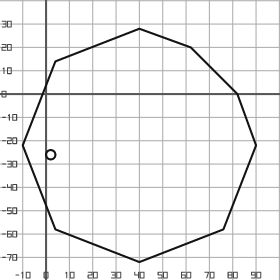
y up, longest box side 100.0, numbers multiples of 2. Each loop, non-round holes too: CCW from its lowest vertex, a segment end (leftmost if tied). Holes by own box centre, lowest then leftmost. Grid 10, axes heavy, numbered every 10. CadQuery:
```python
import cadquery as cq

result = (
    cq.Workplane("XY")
    .moveTo(40.0, -72.0)
    .lineTo(76.0, -58.0)
    .lineTo(90.0, -22.0)
    .lineTo(82.0, 0.0)
    .lineTo(62.0, 20.0)
    .lineTo(40.0, 28.0)
    .lineTo(4.0, 14.0)
    .lineTo(-10.0, -22.0)
    .lineTo(4.0, -58.0)
    .close()
    .moveTo(2.0, -26.0)
    .circle(2.0)
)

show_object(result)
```